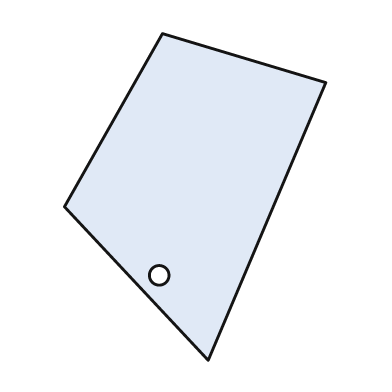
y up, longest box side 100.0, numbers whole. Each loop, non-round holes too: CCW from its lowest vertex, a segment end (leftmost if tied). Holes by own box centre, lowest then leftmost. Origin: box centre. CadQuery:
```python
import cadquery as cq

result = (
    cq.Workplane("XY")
    .moveTo(4.0, -50.0)
    .lineTo(40.0, 35.0)
    .lineTo(-10.0, 50.0)
    .lineTo(-40.0, -3.0)
    .close()
    .moveTo(-11.0, -24.0)
    .circle(3.0)
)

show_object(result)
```